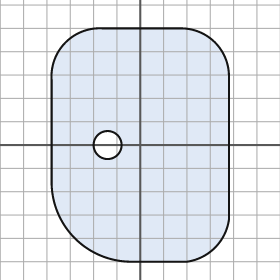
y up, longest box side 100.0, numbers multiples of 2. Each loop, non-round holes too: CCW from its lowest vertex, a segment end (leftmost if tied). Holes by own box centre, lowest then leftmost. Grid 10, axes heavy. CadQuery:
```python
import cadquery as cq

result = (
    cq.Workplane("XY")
    .moveTo(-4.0, -50.0)
    .lineTo(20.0, -50.0)
    .threePointArc((32.0, -44.0), (38.0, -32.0))
    .lineTo(38.0, 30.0)
    .threePointArc((32.0, 44.0), (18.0, 50.0))
    .lineTo(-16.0, 50.0)
    .threePointArc((-32.0, 44.0), (-38.0, 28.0))
    .lineTo(-38.0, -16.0)
    .threePointArc((-28.0, -40.0), (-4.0, -50.0))
    .close()
    .moveTo(-14.0, 0.0)
    .circle(6.0)
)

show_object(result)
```